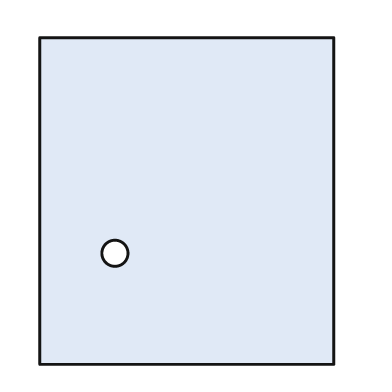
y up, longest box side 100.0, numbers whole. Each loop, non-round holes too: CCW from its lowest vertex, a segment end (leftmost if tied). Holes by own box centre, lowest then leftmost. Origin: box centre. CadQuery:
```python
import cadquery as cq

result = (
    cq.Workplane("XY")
    .moveTo(-45.0, -50.0)
    .lineTo(45.0, -50.0)
    .lineTo(45.0, 50.0)
    .lineTo(-45.0, 50.0)
    .close()
    .moveTo(-22.0, -16.0)
    .circle(4.0)
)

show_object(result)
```